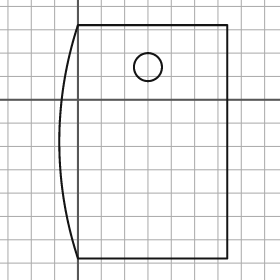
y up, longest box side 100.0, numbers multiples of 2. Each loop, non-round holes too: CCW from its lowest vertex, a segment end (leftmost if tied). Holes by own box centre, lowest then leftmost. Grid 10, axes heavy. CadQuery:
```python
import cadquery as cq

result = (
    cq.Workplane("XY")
    .moveTo(0.0, -68.0)
    .lineTo(64.0, -68.0)
    .lineTo(64.0, 32.0)
    .lineTo(0.0, 32.0)
    .threePointArc((-8.0, -18.0), (0.0, -68.0))
    .close()
    .moveTo(30.0, 14.0)
    .circle(6.0)
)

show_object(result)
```